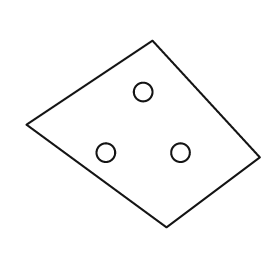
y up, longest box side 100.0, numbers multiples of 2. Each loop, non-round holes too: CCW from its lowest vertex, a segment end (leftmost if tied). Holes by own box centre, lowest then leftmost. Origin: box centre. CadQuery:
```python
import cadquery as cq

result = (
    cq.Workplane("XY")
    .moveTo(10.0, -40.0)
    .lineTo(50.0, -10.0)
    .lineTo(4.0, 40.0)
    .lineTo(-50.0, 4.0)
    .close()
    .moveTo(-16.0, -8.0)
    .circle(4.0)
    .moveTo(16.0, -8.0)
    .circle(4.0)
    .moveTo(0.0, 18.0)
    .circle(4.0)
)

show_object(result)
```